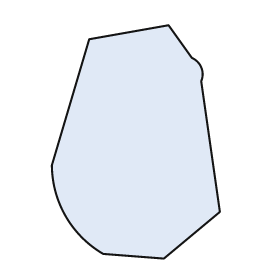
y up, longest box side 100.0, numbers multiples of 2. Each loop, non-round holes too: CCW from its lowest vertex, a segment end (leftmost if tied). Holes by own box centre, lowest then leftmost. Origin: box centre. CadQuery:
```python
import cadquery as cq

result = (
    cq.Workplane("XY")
    .moveTo(12.0, -50.0)
    .lineTo(36.0, -30.0)
    .lineTo(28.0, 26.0)
    .threePointArc((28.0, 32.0), (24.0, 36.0))
    .lineTo(14.0, 50.0)
    .lineTo(-20.0, 44.0)
    .lineTo(-36.0, -10.0)
    .threePointArc((-30.0, -32.0), (-14.0, -48.0))
    .close()
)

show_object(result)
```